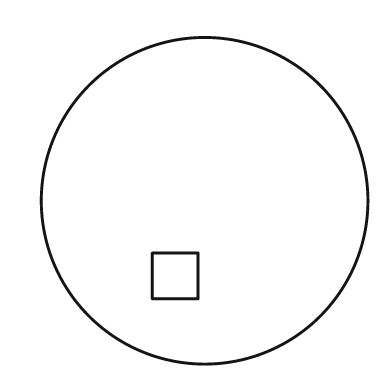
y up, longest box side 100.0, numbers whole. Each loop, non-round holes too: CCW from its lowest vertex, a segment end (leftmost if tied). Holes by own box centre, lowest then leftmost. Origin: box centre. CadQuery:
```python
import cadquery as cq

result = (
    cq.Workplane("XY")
    .moveTo(0.0, 0.0)
    .circle(50.0)
    .moveTo(-16.0, -30.0)
    .lineTo(-2.0, -30.0)
    .lineTo(-2.0, -16.0)
    .lineTo(-16.0, -16.0)
    .close()
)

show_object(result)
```